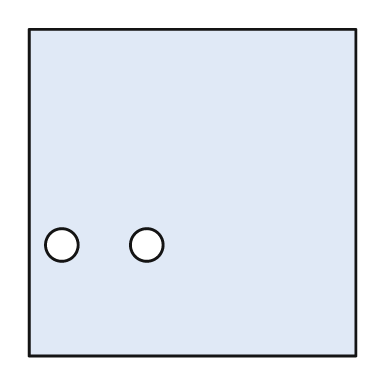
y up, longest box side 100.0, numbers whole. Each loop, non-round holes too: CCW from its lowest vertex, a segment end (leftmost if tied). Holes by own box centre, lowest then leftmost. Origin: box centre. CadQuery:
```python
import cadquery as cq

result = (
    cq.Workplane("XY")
    .moveTo(-50.0, -50.0)
    .lineTo(50.0, -50.0)
    .lineTo(50.0, 50.0)
    .lineTo(-50.0, 50.0)
    .close()
    .moveTo(-40.0, -16.0)
    .circle(5.0)
    .moveTo(-14.0, -16.0)
    .circle(5.0)
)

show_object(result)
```